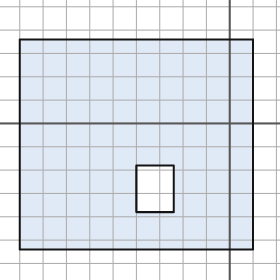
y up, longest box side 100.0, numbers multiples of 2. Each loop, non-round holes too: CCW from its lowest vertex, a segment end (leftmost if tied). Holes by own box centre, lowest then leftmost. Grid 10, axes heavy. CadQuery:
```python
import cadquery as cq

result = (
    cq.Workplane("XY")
    .moveTo(-90.0, -54.0)
    .lineTo(10.0, -54.0)
    .lineTo(10.0, 36.0)
    .lineTo(-90.0, 36.0)
    .close()
    .moveTo(-40.0, -38.0)
    .lineTo(-24.0, -38.0)
    .lineTo(-24.0, -18.0)
    .lineTo(-40.0, -18.0)
    .close()
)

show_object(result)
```